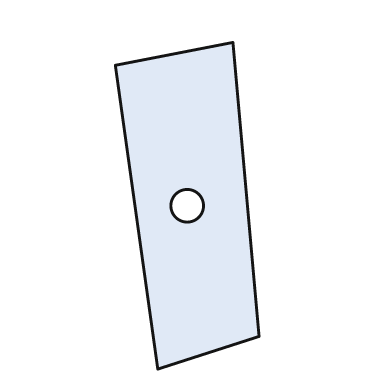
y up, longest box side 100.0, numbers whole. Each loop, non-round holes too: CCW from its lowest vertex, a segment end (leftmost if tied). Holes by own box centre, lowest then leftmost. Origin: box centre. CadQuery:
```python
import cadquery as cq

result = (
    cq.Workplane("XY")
    .moveTo(-9.0, -50.0)
    .lineTo(22.0, -40.0)
    .lineTo(14.0, 50.0)
    .lineTo(-22.0, 43.0)
    .close()
    .moveTo(0.0, 0.0)
    .circle(5.0)
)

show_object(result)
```